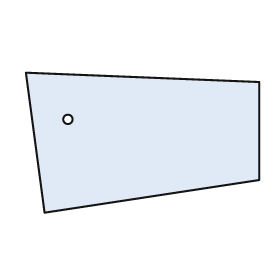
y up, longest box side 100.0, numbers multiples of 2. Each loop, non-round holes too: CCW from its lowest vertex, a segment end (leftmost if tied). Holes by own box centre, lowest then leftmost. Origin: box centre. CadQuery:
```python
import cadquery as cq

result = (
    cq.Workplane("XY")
    .moveTo(-42.0, -30.0)
    .lineTo(50.0, -16.0)
    .lineTo(50.0, 26.0)
    .lineTo(-50.0, 30.0)
    .close()
    .moveTo(-32.0, 10.0)
    .circle(2.0)
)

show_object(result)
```